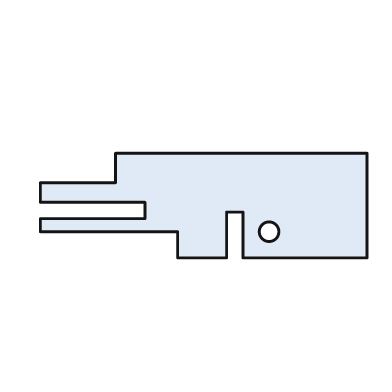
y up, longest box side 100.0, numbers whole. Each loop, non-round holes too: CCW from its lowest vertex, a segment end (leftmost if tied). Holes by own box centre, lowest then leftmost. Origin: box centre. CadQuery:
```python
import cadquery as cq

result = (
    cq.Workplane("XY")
    .moveTo(-8.0, -16.0)
    .lineTo(7.0, -16.0)
    .lineTo(7.0, -2.0)
    .lineTo(12.0, -2.0)
    .lineTo(12.0, -16.0)
    .lineTo(50.0, -16.0)
    .lineTo(50.0, 16.0)
    .lineTo(-27.0, 16.0)
    .lineTo(-27.0, 7.0)
    .lineTo(-50.0, 7.0)
    .lineTo(-50.0, 1.0)
    .lineTo(-18.0, 1.0)
    .lineTo(-18.0, -4.0)
    .lineTo(-50.0, -4.0)
    .lineTo(-50.0, -8.0)
    .lineTo(-8.0, -8.0)
    .close()
    .moveTo(20.0, -8.0)
    .circle(3.0)
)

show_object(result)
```